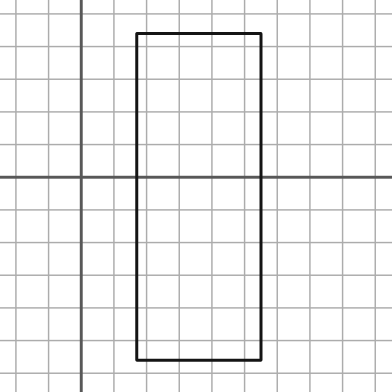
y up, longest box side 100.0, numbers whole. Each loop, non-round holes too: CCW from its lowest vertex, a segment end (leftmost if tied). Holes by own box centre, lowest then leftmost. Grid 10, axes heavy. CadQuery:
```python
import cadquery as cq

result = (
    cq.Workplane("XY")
    .moveTo(17.0, -56.0)
    .lineTo(55.0, -56.0)
    .lineTo(55.0, 44.0)
    .lineTo(17.0, 44.0)
    .close()
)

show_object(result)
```